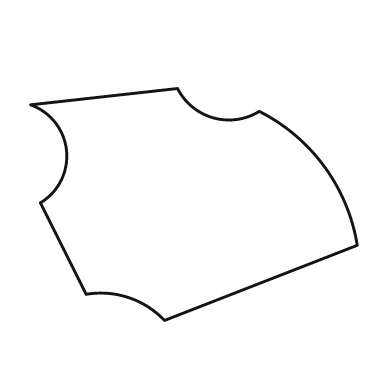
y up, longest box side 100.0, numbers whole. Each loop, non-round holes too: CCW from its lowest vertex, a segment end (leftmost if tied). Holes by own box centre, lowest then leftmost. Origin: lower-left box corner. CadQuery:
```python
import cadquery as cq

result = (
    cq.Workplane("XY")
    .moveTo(41.0, 0.0)
    .lineTo(100.0, 23.0)
    .threePointArc((90.0, 47.0), (70.0, 64.0))
    .threePointArc((56.0, 62.0), (45.0, 71.0))
    .lineTo(0.0, 66.0)
    .threePointArc((11.0, 52.0), (3.0, 36.0))
    .lineTo(17.0, 8.0)
    .threePointArc((30.0, 7.0), (41.0, 0.0))
    .close()
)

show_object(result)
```